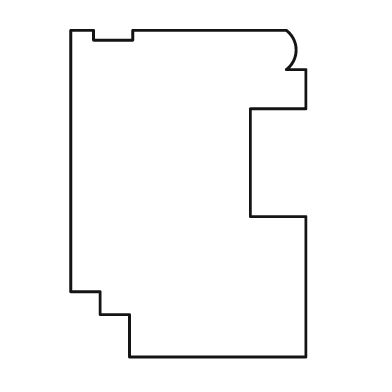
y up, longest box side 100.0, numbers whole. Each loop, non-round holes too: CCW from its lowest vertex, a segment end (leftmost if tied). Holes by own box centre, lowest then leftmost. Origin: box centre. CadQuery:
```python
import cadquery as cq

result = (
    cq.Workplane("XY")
    .moveTo(-18.0, -50.0)
    .lineTo(36.0, -50.0)
    .lineTo(36.0, -7.0)
    .lineTo(19.0, -7.0)
    .lineTo(19.0, 26.0)
    .lineTo(36.0, 26.0)
    .lineTo(36.0, 38.0)
    .lineTo(30.0, 38.0)
    .threePointArc((33.0, 44.0), (30.0, 50.0))
    .lineTo(-17.0, 50.0)
    .lineTo(-17.0, 47.0)
    .lineTo(-29.0, 47.0)
    .lineTo(-29.0, 50.0)
    .lineTo(-36.0, 50.0)
    .lineTo(-36.0, -30.0)
    .lineTo(-27.0, -30.0)
    .lineTo(-27.0, -37.0)
    .lineTo(-18.0, -37.0)
    .close()
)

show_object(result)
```